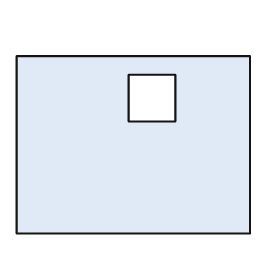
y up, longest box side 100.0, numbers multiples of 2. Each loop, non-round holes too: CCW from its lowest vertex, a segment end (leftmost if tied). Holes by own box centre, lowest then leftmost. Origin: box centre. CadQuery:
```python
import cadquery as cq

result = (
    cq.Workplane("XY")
    .moveTo(-50.0, -38.0)
    .lineTo(50.0, -38.0)
    .lineTo(50.0, 38.0)
    .lineTo(-50.0, 38.0)
    .close()
    .moveTo(-2.0, 10.0)
    .lineTo(18.0, 10.0)
    .lineTo(18.0, 30.0)
    .lineTo(-2.0, 30.0)
    .close()
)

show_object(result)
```